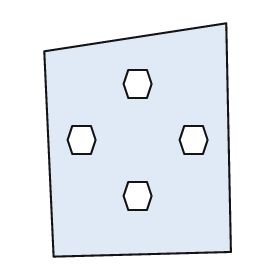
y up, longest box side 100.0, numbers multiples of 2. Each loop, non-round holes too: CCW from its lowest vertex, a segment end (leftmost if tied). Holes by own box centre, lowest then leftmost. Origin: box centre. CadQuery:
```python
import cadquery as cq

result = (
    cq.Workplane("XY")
    .moveTo(-36.0, -50.0)
    .lineTo(40.0, -48.0)
    .lineTo(38.0, 50.0)
    .lineTo(-40.0, 38.0)
    .close()
    .moveTo(-4.0, -30.0)
    .lineTo(4.0, -30.0)
    .lineTo(6.0, -24.0)
    .lineTo(4.0, -18.0)
    .lineTo(-4.0, -18.0)
    .lineTo(-6.0, -24.0)
    .close()
    .moveTo(-28.0, -6.0)
    .lineTo(-20.0, -6.0)
    .lineTo(-18.0, 0.0)
    .lineTo(-20.0, 6.0)
    .lineTo(-28.0, 6.0)
    .lineTo(-30.0, 0.0)
    .close()
    .moveTo(20.0, -6.0)
    .lineTo(28.0, -6.0)
    .lineTo(30.0, 0.0)
    .lineTo(28.0, 6.0)
    .lineTo(20.0, 6.0)
    .lineTo(18.0, 0.0)
    .close()
    .moveTo(-4.0, 18.0)
    .lineTo(4.0, 18.0)
    .lineTo(6.0, 24.0)
    .lineTo(4.0, 30.0)
    .lineTo(-4.0, 30.0)
    .lineTo(-6.0, 24.0)
    .close()
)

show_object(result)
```